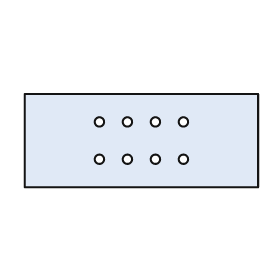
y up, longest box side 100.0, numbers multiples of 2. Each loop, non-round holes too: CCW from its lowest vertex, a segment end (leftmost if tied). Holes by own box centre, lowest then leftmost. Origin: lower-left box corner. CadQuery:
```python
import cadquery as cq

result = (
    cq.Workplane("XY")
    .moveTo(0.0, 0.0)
    .lineTo(100.0, 0.0)
    .lineTo(100.0, 40.0)
    .lineTo(0.0, 40.0)
    .close()
    .moveTo(32.0, 12.0)
    .circle(2.0)
    .moveTo(44.0, 12.0)
    .circle(2.0)
    .moveTo(56.0, 12.0)
    .circle(2.0)
    .moveTo(68.0, 12.0)
    .circle(2.0)
    .moveTo(32.0, 28.0)
    .circle(2.0)
    .moveTo(44.0, 28.0)
    .circle(2.0)
    .moveTo(56.0, 28.0)
    .circle(2.0)
    .moveTo(68.0, 28.0)
    .circle(2.0)
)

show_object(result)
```